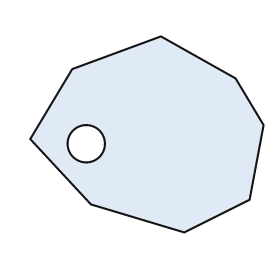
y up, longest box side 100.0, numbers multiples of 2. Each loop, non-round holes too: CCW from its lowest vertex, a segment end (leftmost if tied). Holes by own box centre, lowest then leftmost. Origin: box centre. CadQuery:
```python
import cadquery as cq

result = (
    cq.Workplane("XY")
    .moveTo(16.0, -42.0)
    .lineTo(44.0, -28.0)
    .lineTo(50.0, 4.0)
    .lineTo(38.0, 24.0)
    .lineTo(6.0, 42.0)
    .lineTo(-32.0, 28.0)
    .lineTo(-50.0, -2.0)
    .lineTo(-24.0, -30.0)
    .close()
    .moveTo(-26.0, -4.0)
    .circle(8.0)
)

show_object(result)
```